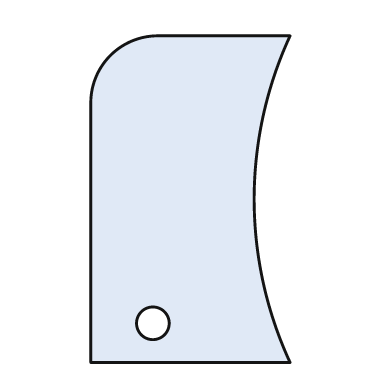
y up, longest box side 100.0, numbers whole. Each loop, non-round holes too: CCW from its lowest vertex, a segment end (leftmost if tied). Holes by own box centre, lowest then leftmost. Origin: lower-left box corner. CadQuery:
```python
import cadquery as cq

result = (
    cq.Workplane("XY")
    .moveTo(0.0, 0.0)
    .lineTo(61.0, 0.0)
    .threePointArc((50.0, 50.0), (61.0, 100.0))
    .lineTo(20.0, 100.0)
    .threePointArc((6.0, 94.0), (0.0, 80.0))
    .close()
    .moveTo(19.0, 12.0)
    .circle(5.0)
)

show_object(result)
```